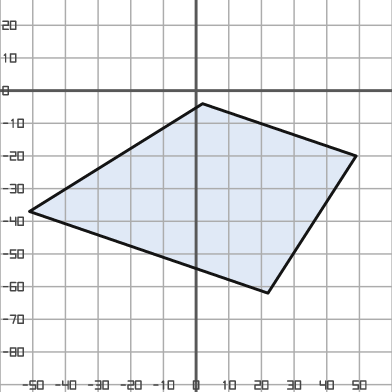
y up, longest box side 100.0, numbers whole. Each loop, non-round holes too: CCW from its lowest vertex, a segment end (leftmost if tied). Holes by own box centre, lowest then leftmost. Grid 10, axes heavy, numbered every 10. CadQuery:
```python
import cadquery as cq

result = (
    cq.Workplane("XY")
    .moveTo(22.0, -62.0)
    .lineTo(49.0, -20.0)
    .lineTo(2.0, -4.0)
    .lineTo(-51.0, -37.0)
    .close()
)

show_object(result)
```